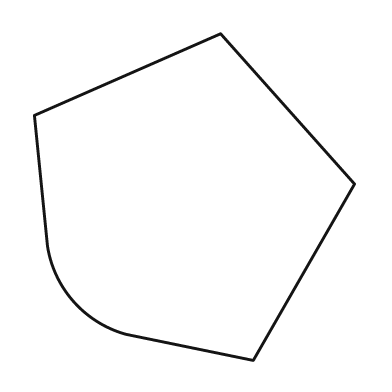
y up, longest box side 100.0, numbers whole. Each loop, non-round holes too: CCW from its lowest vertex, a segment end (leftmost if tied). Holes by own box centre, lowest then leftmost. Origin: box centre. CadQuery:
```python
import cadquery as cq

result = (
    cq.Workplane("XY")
    .moveTo(18.0, -50.0)
    .lineTo(49.0, 4.0)
    .lineTo(8.0, 50.0)
    .lineTo(-49.0, 25.0)
    .lineTo(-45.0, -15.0)
    .threePointArc((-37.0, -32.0), (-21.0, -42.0))
    .close()
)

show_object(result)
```